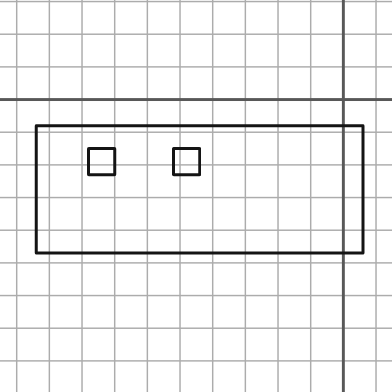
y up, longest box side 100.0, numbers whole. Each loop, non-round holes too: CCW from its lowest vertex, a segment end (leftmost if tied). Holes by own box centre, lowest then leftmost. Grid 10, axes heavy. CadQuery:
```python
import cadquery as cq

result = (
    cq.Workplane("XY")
    .moveTo(-94.0, -47.0)
    .lineTo(6.0, -47.0)
    .lineTo(6.0, -8.0)
    .lineTo(-94.0, -8.0)
    .close()
    .moveTo(-78.0, -23.0)
    .lineTo(-70.0, -23.0)
    .lineTo(-70.0, -15.0)
    .lineTo(-78.0, -15.0)
    .close()
    .moveTo(-52.0, -23.0)
    .lineTo(-44.0, -23.0)
    .lineTo(-44.0, -15.0)
    .lineTo(-52.0, -15.0)
    .close()
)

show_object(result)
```